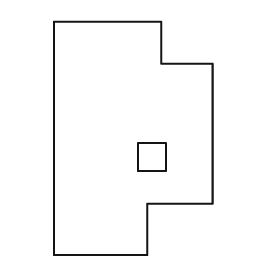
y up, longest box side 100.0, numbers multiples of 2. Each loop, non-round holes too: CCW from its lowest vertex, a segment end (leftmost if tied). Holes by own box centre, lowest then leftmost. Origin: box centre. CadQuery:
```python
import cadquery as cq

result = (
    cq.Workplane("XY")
    .moveTo(-34.0, -50.0)
    .lineTo(6.0, -50.0)
    .lineTo(6.0, -28.0)
    .lineTo(34.0, -28.0)
    .lineTo(34.0, 32.0)
    .lineTo(12.0, 32.0)
    .lineTo(12.0, 50.0)
    .lineTo(-34.0, 50.0)
    .close()
    .moveTo(2.0, -14.0)
    .lineTo(14.0, -14.0)
    .lineTo(14.0, -2.0)
    .lineTo(2.0, -2.0)
    .close()
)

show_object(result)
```